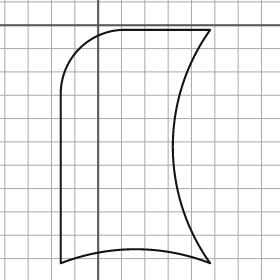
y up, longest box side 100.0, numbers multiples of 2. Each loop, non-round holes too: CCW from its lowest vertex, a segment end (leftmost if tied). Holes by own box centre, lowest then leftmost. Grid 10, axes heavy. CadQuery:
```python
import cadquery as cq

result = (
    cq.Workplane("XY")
    .moveTo(-16.0, -102.0)
    .threePointArc((16.0, -96.0), (48.0, -102.0))
    .threePointArc((32.0, -52.0), (48.0, -2.0))
    .lineTo(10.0, -2.0)
    .threePointArc((-8.0, -10.0), (-16.0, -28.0))
    .close()
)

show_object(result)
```